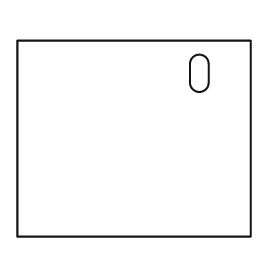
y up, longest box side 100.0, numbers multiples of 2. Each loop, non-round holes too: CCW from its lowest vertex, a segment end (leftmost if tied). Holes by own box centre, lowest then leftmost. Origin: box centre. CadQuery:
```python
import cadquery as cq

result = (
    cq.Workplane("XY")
    .moveTo(-50.0, -42.0)
    .lineTo(50.0, -42.0)
    .lineTo(50.0, 42.0)
    .lineTo(-50.0, 42.0)
    .close()
    .moveTo(24.0, 24.0)
    .threePointArc((28.0, 20.0), (32.0, 24.0))
    .lineTo(32.0, 32.0)
    .threePointArc((28.0, 36.0), (24.0, 32.0))
    .close()
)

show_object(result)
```